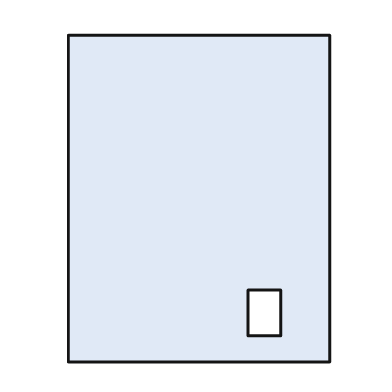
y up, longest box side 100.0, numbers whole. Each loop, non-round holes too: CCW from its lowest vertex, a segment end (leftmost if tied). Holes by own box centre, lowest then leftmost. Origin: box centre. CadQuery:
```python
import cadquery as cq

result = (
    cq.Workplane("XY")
    .moveTo(-40.0, -50.0)
    .lineTo(40.0, -50.0)
    .lineTo(40.0, 50.0)
    .lineTo(-40.0, 50.0)
    .close()
    .moveTo(15.0, -42.0)
    .lineTo(25.0, -42.0)
    .lineTo(25.0, -28.0)
    .lineTo(15.0, -28.0)
    .close()
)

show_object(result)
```